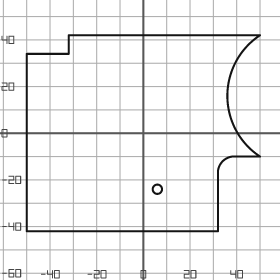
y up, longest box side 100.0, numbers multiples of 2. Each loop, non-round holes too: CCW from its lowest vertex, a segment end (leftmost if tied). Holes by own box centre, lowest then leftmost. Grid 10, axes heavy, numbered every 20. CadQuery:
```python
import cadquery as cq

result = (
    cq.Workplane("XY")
    .moveTo(-50.0, -42.0)
    .lineTo(32.0, -42.0)
    .lineTo(32.0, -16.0)
    .threePointArc((34.0, -12.0), (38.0, -10.0))
    .lineTo(50.0, -10.0)
    .threePointArc((36.0, 16.0), (50.0, 42.0))
    .lineTo(-32.0, 42.0)
    .lineTo(-32.0, 34.0)
    .lineTo(-50.0, 34.0)
    .close()
    .moveTo(6.0, -24.0)
    .circle(2.0)
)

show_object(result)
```